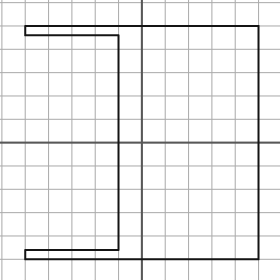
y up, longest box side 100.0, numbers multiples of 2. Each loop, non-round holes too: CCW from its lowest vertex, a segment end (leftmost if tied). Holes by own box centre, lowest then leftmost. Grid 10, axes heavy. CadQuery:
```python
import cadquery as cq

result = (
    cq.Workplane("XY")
    .moveTo(-50.0, -50.0)
    .lineTo(50.0, -50.0)
    .lineTo(50.0, 50.0)
    .lineTo(-50.0, 50.0)
    .lineTo(-50.0, 46.0)
    .lineTo(-10.0, 46.0)
    .lineTo(-10.0, -46.0)
    .lineTo(-50.0, -46.0)
    .close()
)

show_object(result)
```